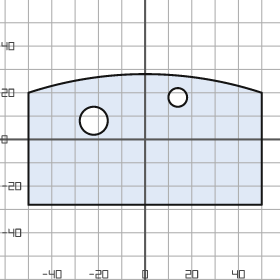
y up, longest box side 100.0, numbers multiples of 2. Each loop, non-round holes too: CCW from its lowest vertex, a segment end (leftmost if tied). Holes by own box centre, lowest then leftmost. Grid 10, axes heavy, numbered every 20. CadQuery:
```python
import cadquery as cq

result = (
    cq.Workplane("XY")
    .moveTo(-50.0, -28.0)
    .lineTo(50.0, -28.0)
    .lineTo(50.0, 20.0)
    .threePointArc((0.0, 28.0), (-50.0, 20.0))
    .close()
    .moveTo(-22.0, 8.0)
    .circle(6.0)
    .moveTo(14.0, 18.0)
    .circle(4.0)
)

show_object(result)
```